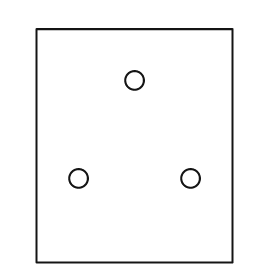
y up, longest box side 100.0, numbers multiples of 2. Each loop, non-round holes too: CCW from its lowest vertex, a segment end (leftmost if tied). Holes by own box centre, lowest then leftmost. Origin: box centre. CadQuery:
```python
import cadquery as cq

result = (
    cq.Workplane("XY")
    .moveTo(-42.0, -50.0)
    .lineTo(42.0, -50.0)
    .lineTo(42.0, 50.0)
    .lineTo(-42.0, 50.0)
    .close()
    .moveTo(-24.0, -14.0)
    .circle(4.0)
    .moveTo(24.0, -14.0)
    .circle(4.0)
    .moveTo(0.0, 28.0)
    .circle(4.0)
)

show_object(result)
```